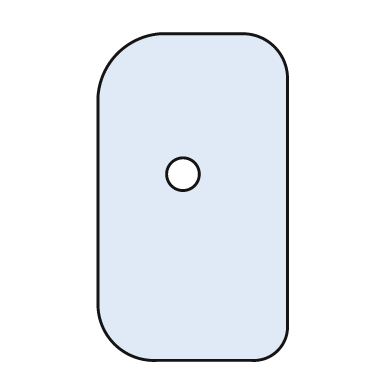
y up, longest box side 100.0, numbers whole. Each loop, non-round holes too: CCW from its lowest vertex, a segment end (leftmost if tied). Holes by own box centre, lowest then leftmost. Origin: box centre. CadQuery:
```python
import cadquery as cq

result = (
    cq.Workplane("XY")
    .moveTo(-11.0, -50.0)
    .lineTo(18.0, -50.0)
    .threePointArc((26.0, -47.0), (29.0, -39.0))
    .lineTo(29.0, 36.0)
    .threePointArc((25.0, 46.0), (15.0, 50.0))
    .lineTo(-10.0, 50.0)
    .threePointArc((-23.0, 44.0), (-29.0, 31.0))
    .lineTo(-29.0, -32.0)
    .threePointArc((-24.0, -45.0), (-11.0, -50.0))
    .close()
    .moveTo(-3.0, 7.0)
    .circle(5.0)
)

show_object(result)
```